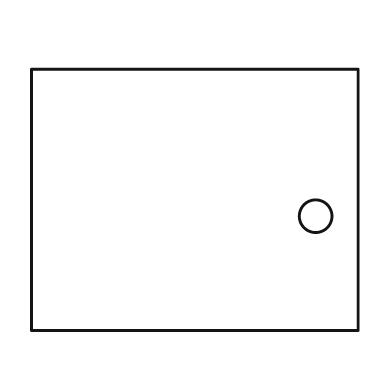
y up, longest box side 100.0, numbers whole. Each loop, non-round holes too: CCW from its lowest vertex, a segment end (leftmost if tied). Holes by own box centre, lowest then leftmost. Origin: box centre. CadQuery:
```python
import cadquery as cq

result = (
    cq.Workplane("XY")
    .moveTo(-50.0, -40.0)
    .lineTo(50.0, -40.0)
    .lineTo(50.0, 40.0)
    .lineTo(-50.0, 40.0)
    .close()
    .moveTo(37.0, -5.0)
    .circle(5.0)
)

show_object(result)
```